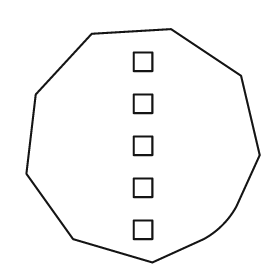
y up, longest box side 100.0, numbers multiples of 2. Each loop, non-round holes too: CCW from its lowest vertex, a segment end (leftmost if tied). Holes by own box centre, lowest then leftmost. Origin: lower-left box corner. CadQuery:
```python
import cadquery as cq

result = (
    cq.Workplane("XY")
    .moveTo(54.0, 0.0)
    .lineTo(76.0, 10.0)
    .threePointArc((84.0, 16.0), (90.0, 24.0))
    .lineTo(100.0, 46.0)
    .lineTo(92.0, 80.0)
    .lineTo(62.0, 100.0)
    .lineTo(28.0, 98.0)
    .lineTo(4.0, 72.0)
    .lineTo(0.0, 38.0)
    .lineTo(20.0, 10.0)
    .close()
    .moveTo(46.0, 10.0)
    .lineTo(54.0, 10.0)
    .lineTo(54.0, 18.0)
    .lineTo(46.0, 18.0)
    .close()
    .moveTo(46.0, 28.0)
    .lineTo(54.0, 28.0)
    .lineTo(54.0, 36.0)
    .lineTo(46.0, 36.0)
    .close()
    .moveTo(46.0, 46.0)
    .lineTo(54.0, 46.0)
    .lineTo(54.0, 54.0)
    .lineTo(46.0, 54.0)
    .close()
    .moveTo(46.0, 64.0)
    .lineTo(54.0, 64.0)
    .lineTo(54.0, 72.0)
    .lineTo(46.0, 72.0)
    .close()
    .moveTo(46.0, 82.0)
    .lineTo(54.0, 82.0)
    .lineTo(54.0, 90.0)
    .lineTo(46.0, 90.0)
    .close()
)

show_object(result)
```